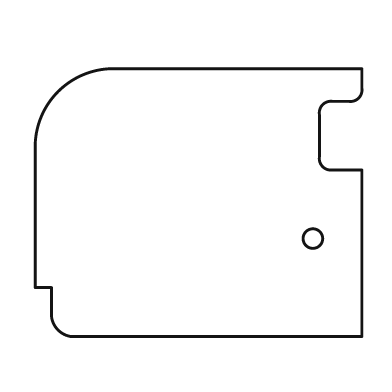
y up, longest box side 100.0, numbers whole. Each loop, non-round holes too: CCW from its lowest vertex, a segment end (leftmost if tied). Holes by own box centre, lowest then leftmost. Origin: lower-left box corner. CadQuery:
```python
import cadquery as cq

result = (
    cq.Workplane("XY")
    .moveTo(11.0, 0.0)
    .lineTo(100.0, 0.0)
    .lineTo(100.0, 51.0)
    .lineTo(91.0, 51.0)
    .threePointArc((88.0, 52.0), (87.0, 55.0))
    .lineTo(87.0, 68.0)
    .threePointArc((88.0, 71.0), (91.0, 72.0))
    .lineTo(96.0, 72.0)
    .threePointArc((99.0, 73.0), (100.0, 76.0))
    .lineTo(100.0, 82.0)
    .lineTo(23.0, 82.0)
    .threePointArc((7.0, 75.0), (0.0, 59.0))
    .lineTo(0.0, 15.0)
    .lineTo(5.0, 15.0)
    .lineTo(5.0, 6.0)
    .threePointArc((7.0, 2.0), (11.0, 0.0))
    .close()
    .moveTo(85.0, 30.0)
    .circle(3.0)
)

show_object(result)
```